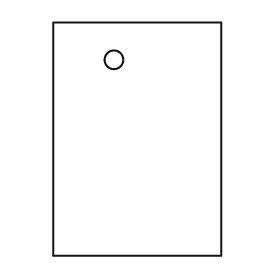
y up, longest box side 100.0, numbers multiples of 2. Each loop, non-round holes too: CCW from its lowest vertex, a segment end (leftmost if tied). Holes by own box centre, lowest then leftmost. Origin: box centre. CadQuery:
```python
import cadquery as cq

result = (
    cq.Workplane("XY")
    .moveTo(-36.0, -50.0)
    .lineTo(36.0, -50.0)
    .lineTo(36.0, 50.0)
    .lineTo(-36.0, 50.0)
    .close()
    .moveTo(-10.0, 34.0)
    .circle(4.0)
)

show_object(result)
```